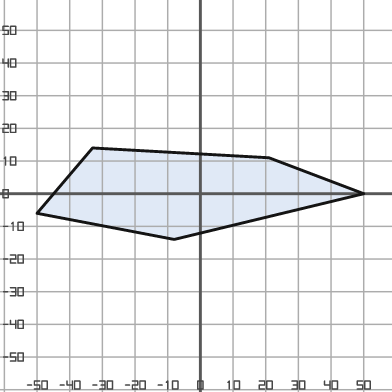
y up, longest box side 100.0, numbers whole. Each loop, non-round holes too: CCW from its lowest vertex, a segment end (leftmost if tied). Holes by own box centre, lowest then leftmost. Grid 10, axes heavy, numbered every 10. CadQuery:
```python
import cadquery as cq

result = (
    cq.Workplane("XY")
    .moveTo(-8.0, -14.0)
    .lineTo(50.0, 0.0)
    .lineTo(21.0, 11.0)
    .lineTo(-33.0, 14.0)
    .lineTo(-50.0, -6.0)
    .close()
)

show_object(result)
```